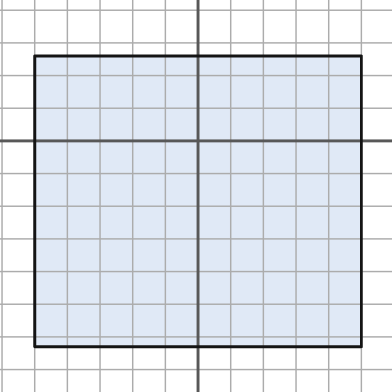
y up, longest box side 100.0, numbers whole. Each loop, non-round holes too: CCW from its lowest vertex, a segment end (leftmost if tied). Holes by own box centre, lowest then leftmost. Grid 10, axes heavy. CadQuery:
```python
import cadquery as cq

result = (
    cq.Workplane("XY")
    .moveTo(-50.0, -63.0)
    .lineTo(50.0, -63.0)
    .lineTo(50.0, 26.0)
    .lineTo(-50.0, 26.0)
    .close()
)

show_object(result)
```